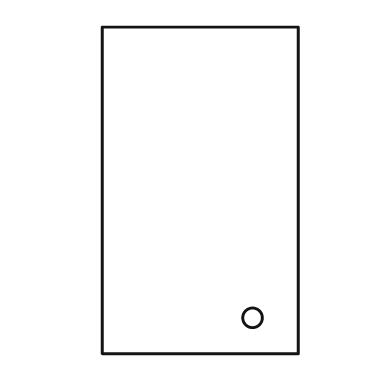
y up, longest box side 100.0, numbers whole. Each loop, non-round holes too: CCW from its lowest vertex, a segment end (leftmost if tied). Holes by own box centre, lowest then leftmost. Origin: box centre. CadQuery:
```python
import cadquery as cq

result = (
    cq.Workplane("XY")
    .moveTo(-30.0, -50.0)
    .lineTo(30.0, -50.0)
    .lineTo(30.0, 50.0)
    .lineTo(-30.0, 50.0)
    .close()
    .moveTo(16.0, -39.0)
    .circle(3.0)
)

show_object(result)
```